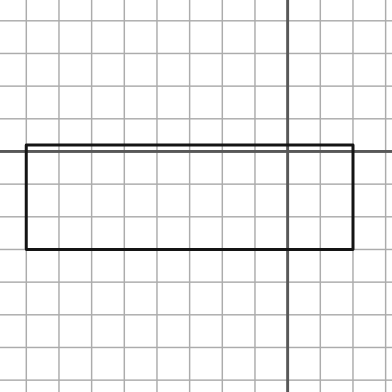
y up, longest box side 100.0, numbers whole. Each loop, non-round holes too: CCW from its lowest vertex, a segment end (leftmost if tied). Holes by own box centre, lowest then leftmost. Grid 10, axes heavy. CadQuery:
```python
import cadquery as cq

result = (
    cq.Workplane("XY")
    .moveTo(-80.0, -30.0)
    .lineTo(20.0, -30.0)
    .lineTo(20.0, 2.0)
    .lineTo(-80.0, 2.0)
    .close()
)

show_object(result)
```